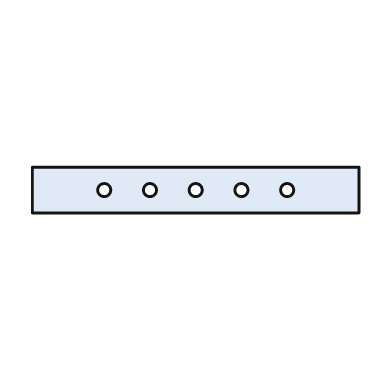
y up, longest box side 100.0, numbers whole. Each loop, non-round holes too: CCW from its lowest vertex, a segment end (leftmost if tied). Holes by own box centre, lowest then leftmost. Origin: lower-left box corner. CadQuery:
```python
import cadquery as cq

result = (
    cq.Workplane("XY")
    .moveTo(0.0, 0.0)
    .lineTo(100.0, 0.0)
    .lineTo(100.0, 14.0)
    .lineTo(0.0, 14.0)
    .close()
    .moveTo(22.0, 7.0)
    .circle(2.0)
    .moveTo(36.0, 7.0)
    .circle(2.0)
    .moveTo(50.0, 7.0)
    .circle(2.0)
    .moveTo(64.0, 7.0)
    .circle(2.0)
    .moveTo(78.0, 7.0)
    .circle(2.0)
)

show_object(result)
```